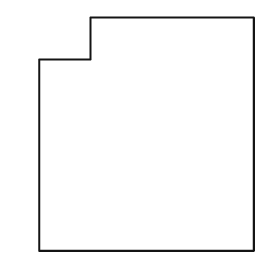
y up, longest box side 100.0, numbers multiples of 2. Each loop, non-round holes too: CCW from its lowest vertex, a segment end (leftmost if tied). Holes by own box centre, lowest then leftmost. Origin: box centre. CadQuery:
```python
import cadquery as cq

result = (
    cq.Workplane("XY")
    .moveTo(-46.0, -50.0)
    .lineTo(46.0, -50.0)
    .lineTo(46.0, 50.0)
    .lineTo(-24.0, 50.0)
    .lineTo(-24.0, 32.0)
    .lineTo(-46.0, 32.0)
    .close()
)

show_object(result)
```